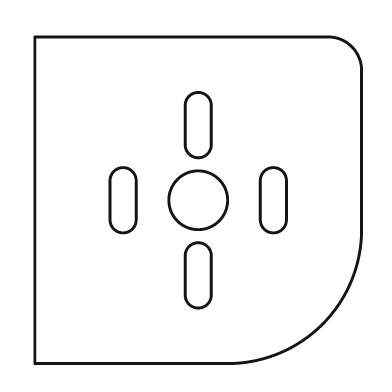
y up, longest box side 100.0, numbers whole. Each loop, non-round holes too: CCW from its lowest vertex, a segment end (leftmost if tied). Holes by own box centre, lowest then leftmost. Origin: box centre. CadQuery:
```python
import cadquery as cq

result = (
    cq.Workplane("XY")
    .moveTo(-50.0, -50.0)
    .lineTo(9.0, -50.0)
    .threePointArc((38.0, -38.0), (50.0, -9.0))
    .lineTo(50.0, 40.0)
    .threePointArc((47.0, 47.0), (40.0, 50.0))
    .lineTo(-50.0, 50.0)
    .close()
    .moveTo(-4.0, -29.0)
    .threePointArc((0.0, -33.0), (4.0, -29.0))
    .lineTo(4.0, -17.0)
    .threePointArc((0.0, -13.0), (-4.0, -17.0))
    .close()
    .moveTo(-27.0, -6.0)
    .threePointArc((-23.0, -10.0), (-19.0, -6.0))
    .lineTo(-19.0, 6.0)
    .threePointArc((-23.0, 10.0), (-27.0, 6.0))
    .close()
    .moveTo(0.0, 0.0)
    .circle(9.0)
    .moveTo(19.0, -6.0)
    .threePointArc((23.0, -10.0), (27.0, -6.0))
    .lineTo(27.0, 6.0)
    .threePointArc((23.0, 10.0), (19.0, 6.0))
    .close()
    .moveTo(-4.0, 17.0)
    .threePointArc((0.0, 13.0), (4.0, 17.0))
    .lineTo(4.0, 29.0)
    .threePointArc((0.0, 33.0), (-4.0, 29.0))
    .close()
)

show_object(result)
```